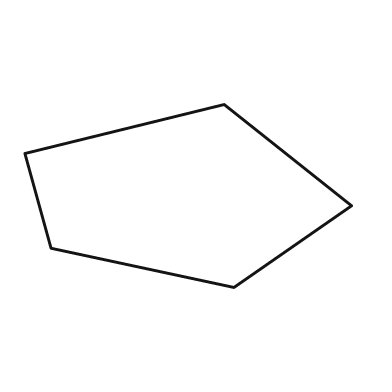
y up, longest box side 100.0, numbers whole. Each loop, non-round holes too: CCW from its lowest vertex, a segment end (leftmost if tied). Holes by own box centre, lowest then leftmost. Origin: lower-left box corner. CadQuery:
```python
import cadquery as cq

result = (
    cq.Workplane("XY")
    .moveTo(64.0, 0.0)
    .lineTo(100.0, 25.0)
    .lineTo(61.0, 56.0)
    .lineTo(0.0, 41.0)
    .lineTo(8.0, 12.0)
    .close()
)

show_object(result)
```